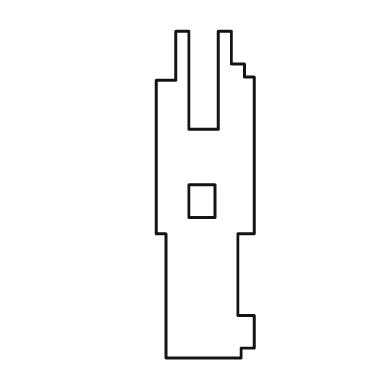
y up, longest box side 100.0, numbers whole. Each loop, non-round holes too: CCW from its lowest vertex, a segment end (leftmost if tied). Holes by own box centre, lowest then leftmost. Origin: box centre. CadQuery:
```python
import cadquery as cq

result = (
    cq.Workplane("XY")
    .moveTo(-12.0, -50.0)
    .lineTo(11.0, -50.0)
    .lineTo(11.0, -47.0)
    .lineTo(15.0, -47.0)
    .lineTo(15.0, -37.0)
    .lineTo(10.0, -37.0)
    .lineTo(10.0, -12.0)
    .lineTo(15.0, -12.0)
    .lineTo(15.0, 36.0)
    .lineTo(12.0, 36.0)
    .lineTo(12.0, 40.0)
    .lineTo(8.0, 40.0)
    .lineTo(8.0, 50.0)
    .lineTo(4.0, 50.0)
    .lineTo(4.0, 20.0)
    .lineTo(-5.0, 20.0)
    .lineTo(-5.0, 50.0)
    .lineTo(-9.0, 50.0)
    .lineTo(-9.0, 35.0)
    .lineTo(-15.0, 35.0)
    .lineTo(-15.0, -12.0)
    .lineTo(-12.0, -12.0)
    .close()
    .moveTo(-5.0, -7.0)
    .lineTo(3.0, -7.0)
    .lineTo(3.0, 3.0)
    .lineTo(-5.0, 3.0)
    .close()
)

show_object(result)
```